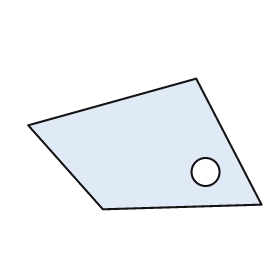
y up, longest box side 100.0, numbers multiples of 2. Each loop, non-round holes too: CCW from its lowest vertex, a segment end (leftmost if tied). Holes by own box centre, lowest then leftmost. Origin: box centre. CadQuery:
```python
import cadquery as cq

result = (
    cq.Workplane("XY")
    .moveTo(-18.0, -28.0)
    .lineTo(50.0, -26.0)
    .lineTo(22.0, 28.0)
    .lineTo(-50.0, 8.0)
    .close()
    .moveTo(26.0, -12.0)
    .circle(6.0)
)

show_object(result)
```